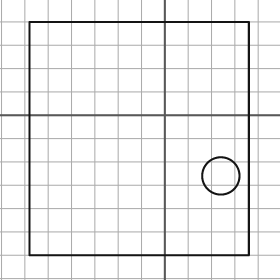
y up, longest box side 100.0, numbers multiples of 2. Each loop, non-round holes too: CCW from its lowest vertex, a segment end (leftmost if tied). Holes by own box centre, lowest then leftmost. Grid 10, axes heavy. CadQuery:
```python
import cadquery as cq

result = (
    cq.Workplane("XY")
    .moveTo(-58.0, -60.0)
    .lineTo(36.0, -60.0)
    .lineTo(36.0, 40.0)
    .lineTo(-58.0, 40.0)
    .close()
    .moveTo(24.0, -26.0)
    .circle(8.0)
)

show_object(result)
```